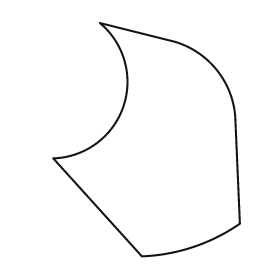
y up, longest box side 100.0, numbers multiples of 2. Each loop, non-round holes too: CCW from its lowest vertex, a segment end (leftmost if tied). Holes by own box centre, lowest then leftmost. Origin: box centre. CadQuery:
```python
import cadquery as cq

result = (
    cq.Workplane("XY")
    .moveTo(-2.0, -50.0)
    .threePointArc((20.0, -46.0), (40.0, -36.0))
    .lineTo(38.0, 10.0)
    .threePointArc((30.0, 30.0), (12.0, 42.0))
    .lineTo(-20.0, 50.0)
    .threePointArc((-10.0, 14.0), (-40.0, -8.0))
    .close()
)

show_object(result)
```